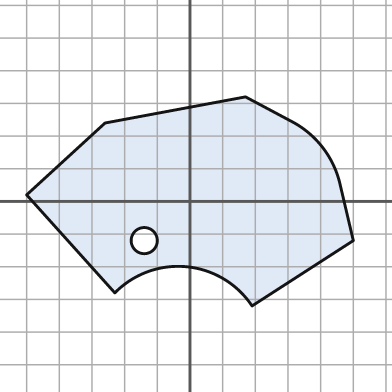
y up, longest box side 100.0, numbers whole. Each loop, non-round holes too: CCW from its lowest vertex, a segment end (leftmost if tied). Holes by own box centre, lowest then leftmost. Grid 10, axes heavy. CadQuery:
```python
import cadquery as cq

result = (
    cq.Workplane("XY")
    .moveTo(19.0, -32.0)
    .lineTo(50.0, -12.0)
    .lineTo(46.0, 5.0)
    .threePointArc((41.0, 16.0), (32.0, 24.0))
    .lineTo(17.0, 32.0)
    .lineTo(-26.0, 24.0)
    .lineTo(-50.0, 2.0)
    .lineTo(-23.0, -28.0)
    .threePointArc((-1.0, -20.0), (19.0, -32.0))
    .close()
    .moveTo(-14.0, -12.0)
    .circle(4.0)
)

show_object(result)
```